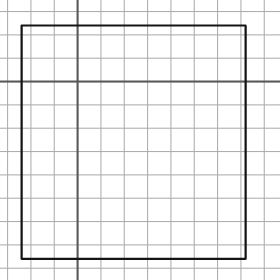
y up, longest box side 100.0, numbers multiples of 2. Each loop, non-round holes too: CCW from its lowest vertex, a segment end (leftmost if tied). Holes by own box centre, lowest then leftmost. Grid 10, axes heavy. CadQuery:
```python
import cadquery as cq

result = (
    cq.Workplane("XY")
    .moveTo(-24.0, -76.0)
    .lineTo(72.0, -76.0)
    .lineTo(72.0, 24.0)
    .lineTo(-24.0, 24.0)
    .close()
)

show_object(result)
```